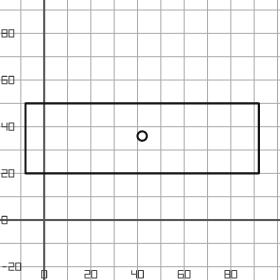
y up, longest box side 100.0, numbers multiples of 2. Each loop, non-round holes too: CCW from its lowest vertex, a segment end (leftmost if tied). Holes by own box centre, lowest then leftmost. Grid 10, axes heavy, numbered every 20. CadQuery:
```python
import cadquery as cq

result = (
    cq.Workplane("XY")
    .moveTo(-8.0, 20.0)
    .lineTo(92.0, 20.0)
    .lineTo(92.0, 50.0)
    .lineTo(-8.0, 50.0)
    .close()
    .moveTo(42.0, 36.0)
    .circle(2.0)
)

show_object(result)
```